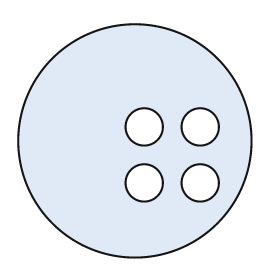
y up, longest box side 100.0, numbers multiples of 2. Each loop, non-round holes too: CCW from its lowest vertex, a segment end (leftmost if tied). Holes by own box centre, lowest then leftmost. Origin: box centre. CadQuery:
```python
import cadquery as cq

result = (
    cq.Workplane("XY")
    .moveTo(0.0, 0.0)
    .circle(50.0)
    .moveTo(4.0, -18.0)
    .circle(8.0)
    .moveTo(28.0, -18.0)
    .circle(8.0)
    .moveTo(4.0, 6.0)
    .circle(8.0)
    .moveTo(28.0, 6.0)
    .circle(8.0)
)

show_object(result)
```